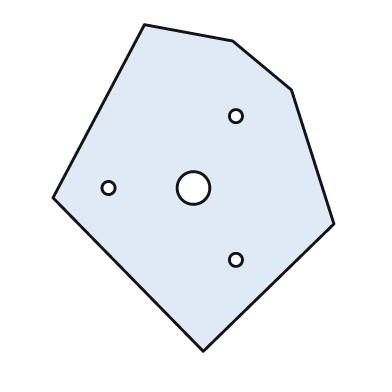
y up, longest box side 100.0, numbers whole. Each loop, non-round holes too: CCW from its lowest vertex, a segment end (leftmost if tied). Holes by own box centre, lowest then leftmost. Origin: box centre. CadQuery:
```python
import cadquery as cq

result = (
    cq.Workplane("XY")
    .moveTo(3.0, -50.0)
    .lineTo(43.0, -11.0)
    .lineTo(30.0, 30.0)
    .lineTo(12.0, 45.0)
    .lineTo(-15.0, 50.0)
    .lineTo(-43.0, -3.0)
    .close()
    .moveTo(13.0, -22.0)
    .circle(2.0)
    .moveTo(-26.0, 0.0)
    .circle(2.0)
    .moveTo(0.0, 0.0)
    .circle(5.0)
    .moveTo(13.0, 22.0)
    .circle(2.0)
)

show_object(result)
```